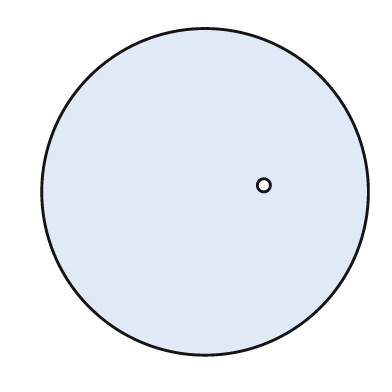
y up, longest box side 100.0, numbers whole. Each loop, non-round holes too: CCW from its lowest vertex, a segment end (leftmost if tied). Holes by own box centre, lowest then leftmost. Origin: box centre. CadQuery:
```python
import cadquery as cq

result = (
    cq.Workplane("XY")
    .moveTo(0.0, 0.0)
    .circle(50.0)
    .moveTo(18.0, 2.0)
    .circle(2.0)
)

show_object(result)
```